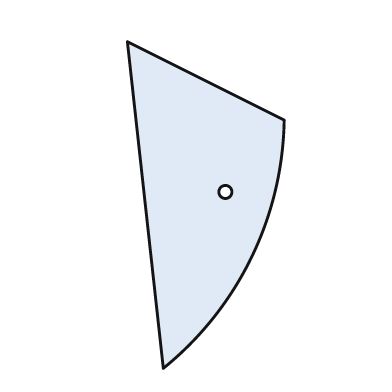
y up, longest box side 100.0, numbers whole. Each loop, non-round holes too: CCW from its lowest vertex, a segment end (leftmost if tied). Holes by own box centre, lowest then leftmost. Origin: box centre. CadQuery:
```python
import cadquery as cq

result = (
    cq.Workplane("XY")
    .moveTo(-13.0, -50.0)
    .threePointArc((14.0, -16.0), (24.0, 26.0))
    .lineTo(-24.0, 50.0)
    .close()
    .moveTo(6.0, 4.0)
    .circle(2.0)
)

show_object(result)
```